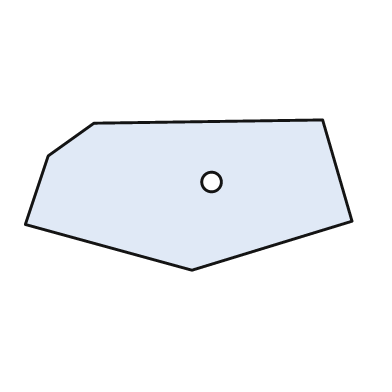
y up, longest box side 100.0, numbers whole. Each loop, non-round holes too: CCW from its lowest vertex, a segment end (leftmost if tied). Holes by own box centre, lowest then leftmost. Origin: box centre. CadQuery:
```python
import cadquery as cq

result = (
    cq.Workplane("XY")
    .moveTo(1.0, -23.0)
    .lineTo(50.0, -8.0)
    .lineTo(41.0, 23.0)
    .lineTo(-29.0, 22.0)
    .lineTo(-43.0, 12.0)
    .lineTo(-50.0, -9.0)
    .close()
    .moveTo(7.0, 4.0)
    .circle(3.0)
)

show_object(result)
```